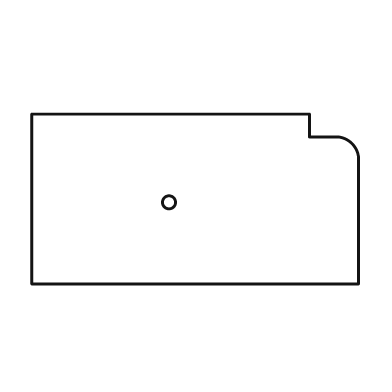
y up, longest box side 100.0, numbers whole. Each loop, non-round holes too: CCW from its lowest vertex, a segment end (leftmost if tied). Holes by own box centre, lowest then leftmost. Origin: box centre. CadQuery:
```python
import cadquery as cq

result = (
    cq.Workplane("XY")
    .moveTo(-50.0, -26.0)
    .lineTo(50.0, -26.0)
    .lineTo(50.0, 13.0)
    .threePointArc((48.0, 17.0), (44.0, 19.0))
    .lineTo(35.0, 19.0)
    .lineTo(35.0, 26.0)
    .lineTo(-50.0, 26.0)
    .close()
    .moveTo(-8.0, -1.0)
    .circle(2.0)
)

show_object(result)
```